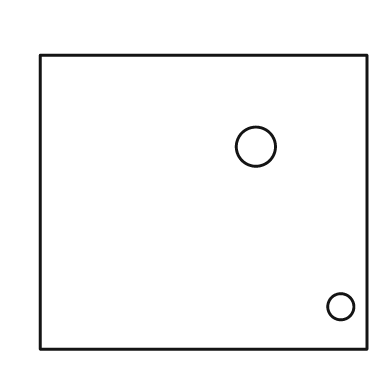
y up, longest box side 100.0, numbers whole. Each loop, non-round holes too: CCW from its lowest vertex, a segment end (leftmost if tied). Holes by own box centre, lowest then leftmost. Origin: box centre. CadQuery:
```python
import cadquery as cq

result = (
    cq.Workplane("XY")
    .moveTo(-50.0, -45.0)
    .lineTo(50.0, -45.0)
    .lineTo(50.0, 45.0)
    .lineTo(-50.0, 45.0)
    .close()
    .moveTo(42.0, -32.0)
    .circle(4.0)
    .moveTo(16.0, 17.0)
    .circle(6.0)
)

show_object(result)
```